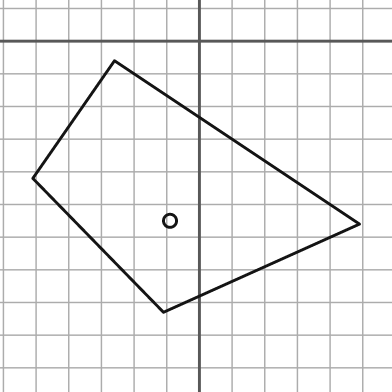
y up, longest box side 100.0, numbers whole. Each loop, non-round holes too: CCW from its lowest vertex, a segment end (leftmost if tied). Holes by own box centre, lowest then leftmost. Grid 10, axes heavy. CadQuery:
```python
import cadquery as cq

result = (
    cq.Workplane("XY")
    .moveTo(-11.0, -83.0)
    .lineTo(49.0, -56.0)
    .lineTo(-26.0, -6.0)
    .lineTo(-51.0, -42.0)
    .close()
    .moveTo(-9.0, -55.0)
    .circle(2.0)
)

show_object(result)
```